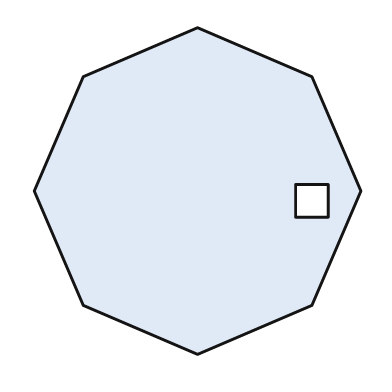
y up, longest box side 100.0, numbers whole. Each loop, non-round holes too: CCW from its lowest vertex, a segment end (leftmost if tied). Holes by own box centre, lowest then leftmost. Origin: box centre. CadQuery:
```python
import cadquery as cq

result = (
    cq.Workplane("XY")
    .moveTo(0.0, -50.0)
    .lineTo(35.0, -35.0)
    .lineTo(50.0, 0.0)
    .lineTo(35.0, 35.0)
    .lineTo(0.0, 50.0)
    .lineTo(-35.0, 35.0)
    .lineTo(-50.0, 0.0)
    .lineTo(-35.0, -35.0)
    .close()
    .moveTo(30.0, -8.0)
    .lineTo(40.0, -8.0)
    .lineTo(40.0, 2.0)
    .lineTo(30.0, 2.0)
    .close()
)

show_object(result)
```